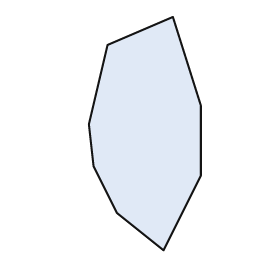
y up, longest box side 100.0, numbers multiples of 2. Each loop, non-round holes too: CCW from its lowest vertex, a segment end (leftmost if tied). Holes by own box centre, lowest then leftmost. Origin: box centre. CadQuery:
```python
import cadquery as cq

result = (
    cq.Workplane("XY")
    .moveTo(8.0, -50.0)
    .lineTo(24.0, -18.0)
    .lineTo(24.0, 12.0)
    .lineTo(12.0, 50.0)
    .lineTo(-16.0, 38.0)
    .lineTo(-24.0, 4.0)
    .lineTo(-22.0, -14.0)
    .lineTo(-12.0, -34.0)
    .close()
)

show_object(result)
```